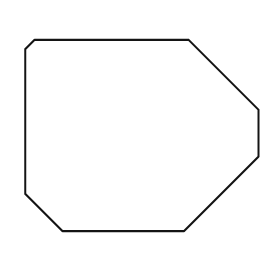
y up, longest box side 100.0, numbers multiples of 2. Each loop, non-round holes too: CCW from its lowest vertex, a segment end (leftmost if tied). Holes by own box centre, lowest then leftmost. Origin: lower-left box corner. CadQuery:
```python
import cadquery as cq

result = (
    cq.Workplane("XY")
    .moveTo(16.0, 0.0)
    .lineTo(68.0, 0.0)
    .lineTo(100.0, 32.0)
    .lineTo(100.0, 52.0)
    .lineTo(70.0, 82.0)
    .lineTo(4.0, 82.0)
    .lineTo(0.0, 78.0)
    .lineTo(0.0, 16.0)
    .close()
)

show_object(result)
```